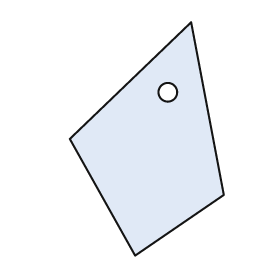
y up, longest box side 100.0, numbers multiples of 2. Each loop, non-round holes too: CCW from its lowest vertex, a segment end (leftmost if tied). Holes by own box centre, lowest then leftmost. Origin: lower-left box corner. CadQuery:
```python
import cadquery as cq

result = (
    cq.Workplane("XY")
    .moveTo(28.0, 0.0)
    .lineTo(66.0, 26.0)
    .lineTo(52.0, 100.0)
    .lineTo(0.0, 50.0)
    .close()
    .moveTo(42.0, 70.0)
    .circle(4.0)
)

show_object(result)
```